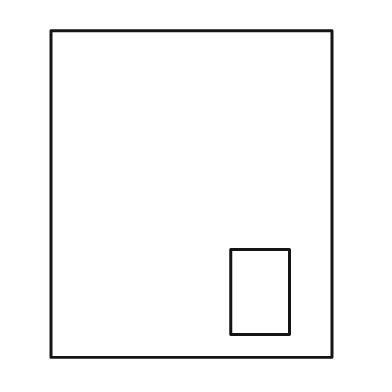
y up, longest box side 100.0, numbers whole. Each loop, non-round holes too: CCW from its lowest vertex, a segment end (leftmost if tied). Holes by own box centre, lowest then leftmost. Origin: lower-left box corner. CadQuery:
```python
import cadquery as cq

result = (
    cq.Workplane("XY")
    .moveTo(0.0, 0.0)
    .lineTo(86.0, 0.0)
    .lineTo(86.0, 100.0)
    .lineTo(0.0, 100.0)
    .close()
    .moveTo(55.0, 7.0)
    .lineTo(73.0, 7.0)
    .lineTo(73.0, 33.0)
    .lineTo(55.0, 33.0)
    .close()
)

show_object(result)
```